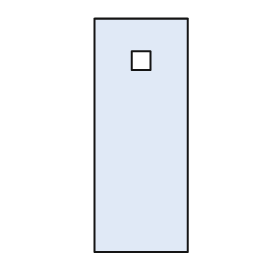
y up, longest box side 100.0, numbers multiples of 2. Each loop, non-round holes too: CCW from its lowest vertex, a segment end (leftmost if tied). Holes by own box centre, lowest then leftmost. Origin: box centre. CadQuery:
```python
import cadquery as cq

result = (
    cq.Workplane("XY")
    .moveTo(-20.0, -50.0)
    .lineTo(20.0, -50.0)
    .lineTo(20.0, 50.0)
    .lineTo(-20.0, 50.0)
    .close()
    .moveTo(-4.0, 28.0)
    .lineTo(4.0, 28.0)
    .lineTo(4.0, 36.0)
    .lineTo(-4.0, 36.0)
    .close()
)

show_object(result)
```